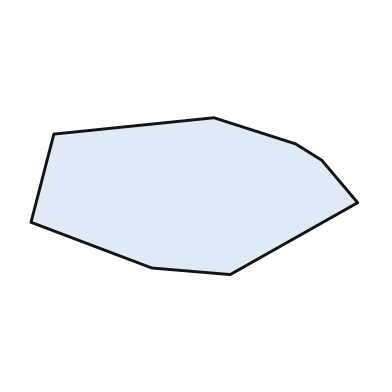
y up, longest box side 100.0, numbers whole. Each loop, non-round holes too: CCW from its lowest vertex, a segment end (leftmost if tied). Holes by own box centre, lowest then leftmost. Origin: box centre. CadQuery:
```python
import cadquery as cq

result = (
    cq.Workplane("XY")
    .moveTo(11.0, -24.0)
    .lineTo(50.0, -2.0)
    .lineTo(39.0, 11.0)
    .lineTo(31.0, 16.0)
    .lineTo(6.0, 24.0)
    .lineTo(-43.0, 19.0)
    .lineTo(-50.0, -8.0)
    .lineTo(-13.0, -22.0)
    .close()
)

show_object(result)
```